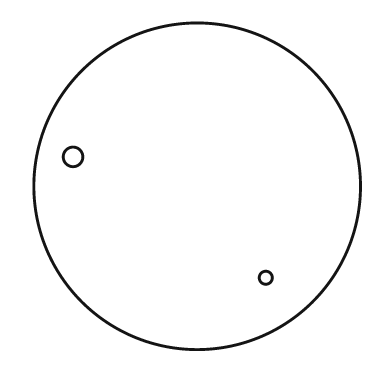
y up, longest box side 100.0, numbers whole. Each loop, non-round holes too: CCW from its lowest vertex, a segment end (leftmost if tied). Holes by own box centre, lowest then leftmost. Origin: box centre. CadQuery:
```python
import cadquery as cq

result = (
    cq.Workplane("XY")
    .moveTo(0.0, 0.0)
    .circle(50.0)
    .moveTo(21.0, -28.0)
    .circle(2.0)
    .moveTo(-38.0, 9.0)
    .circle(3.0)
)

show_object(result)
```